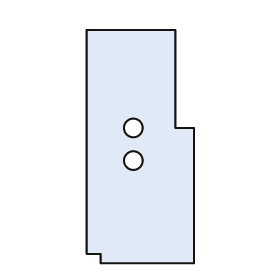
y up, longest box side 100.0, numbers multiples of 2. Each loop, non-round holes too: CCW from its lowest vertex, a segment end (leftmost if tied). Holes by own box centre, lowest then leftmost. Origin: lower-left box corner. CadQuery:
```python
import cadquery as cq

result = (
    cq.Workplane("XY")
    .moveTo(6.0, 0.0)
    .lineTo(46.0, 0.0)
    .lineTo(46.0, 58.0)
    .lineTo(38.0, 58.0)
    .lineTo(38.0, 100.0)
    .lineTo(0.0, 100.0)
    .lineTo(0.0, 4.0)
    .lineTo(6.0, 4.0)
    .close()
    .moveTo(20.0, 44.0)
    .circle(4.0)
    .moveTo(20.0, 58.0)
    .circle(4.0)
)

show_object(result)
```